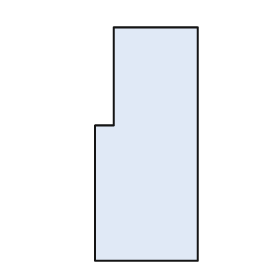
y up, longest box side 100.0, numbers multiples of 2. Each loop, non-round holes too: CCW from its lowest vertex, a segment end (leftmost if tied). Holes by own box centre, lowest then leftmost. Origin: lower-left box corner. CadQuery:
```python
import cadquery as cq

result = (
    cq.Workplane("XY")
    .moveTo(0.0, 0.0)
    .lineTo(44.0, 0.0)
    .lineTo(44.0, 100.0)
    .lineTo(8.0, 100.0)
    .lineTo(8.0, 58.0)
    .lineTo(0.0, 58.0)
    .close()
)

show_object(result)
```